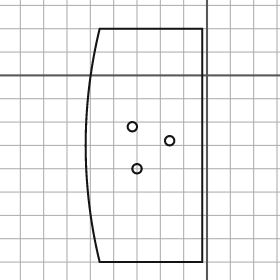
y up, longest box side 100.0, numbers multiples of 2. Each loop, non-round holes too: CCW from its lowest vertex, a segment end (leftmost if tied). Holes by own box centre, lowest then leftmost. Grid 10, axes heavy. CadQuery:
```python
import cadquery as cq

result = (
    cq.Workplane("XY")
    .moveTo(-46.0, -80.0)
    .lineTo(-2.0, -80.0)
    .lineTo(-2.0, 20.0)
    .lineTo(-46.0, 20.0)
    .threePointArc((-52.0, -30.0), (-46.0, -80.0))
    .close()
    .moveTo(-30.0, -40.0)
    .circle(2.0)
    .moveTo(-16.0, -28.0)
    .circle(2.0)
    .moveTo(-32.0, -22.0)
    .circle(2.0)
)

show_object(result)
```